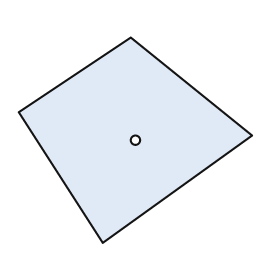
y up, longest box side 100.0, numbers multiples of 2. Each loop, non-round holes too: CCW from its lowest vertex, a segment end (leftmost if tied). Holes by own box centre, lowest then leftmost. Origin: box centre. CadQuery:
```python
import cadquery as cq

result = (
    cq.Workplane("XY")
    .moveTo(-14.0, -44.0)
    .lineTo(50.0, 2.0)
    .lineTo(-2.0, 44.0)
    .lineTo(-50.0, 12.0)
    .close()
    .moveTo(0.0, 0.0)
    .circle(2.0)
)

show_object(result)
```